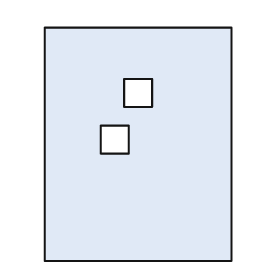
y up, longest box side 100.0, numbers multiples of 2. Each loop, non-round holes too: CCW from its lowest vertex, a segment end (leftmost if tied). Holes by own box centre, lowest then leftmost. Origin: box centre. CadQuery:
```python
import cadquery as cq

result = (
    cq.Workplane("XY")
    .moveTo(-40.0, -50.0)
    .lineTo(40.0, -50.0)
    .lineTo(40.0, 50.0)
    .lineTo(-40.0, 50.0)
    .close()
    .moveTo(-16.0, -4.0)
    .lineTo(-4.0, -4.0)
    .lineTo(-4.0, 8.0)
    .lineTo(-16.0, 8.0)
    .close()
    .moveTo(-6.0, 16.0)
    .lineTo(6.0, 16.0)
    .lineTo(6.0, 28.0)
    .lineTo(-6.0, 28.0)
    .close()
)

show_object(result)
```